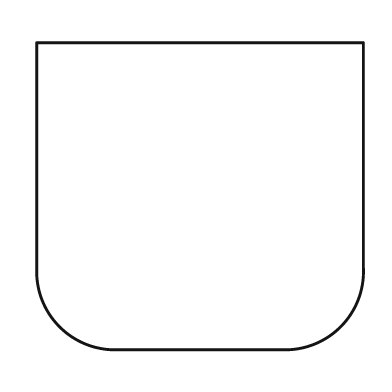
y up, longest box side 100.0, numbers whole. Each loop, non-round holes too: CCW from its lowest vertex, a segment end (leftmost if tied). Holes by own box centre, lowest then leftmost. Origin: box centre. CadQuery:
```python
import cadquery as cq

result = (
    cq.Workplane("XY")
    .moveTo(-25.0, -47.0)
    .lineTo(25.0, -47.0)
    .threePointArc((43.0, -40.0), (50.0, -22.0))
    .lineTo(50.0, 47.0)
    .lineTo(-50.0, 47.0)
    .lineTo(-50.0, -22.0)
    .threePointArc((-43.0, -40.0), (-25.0, -47.0))
    .close()
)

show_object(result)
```